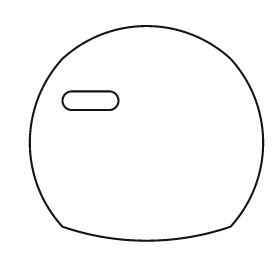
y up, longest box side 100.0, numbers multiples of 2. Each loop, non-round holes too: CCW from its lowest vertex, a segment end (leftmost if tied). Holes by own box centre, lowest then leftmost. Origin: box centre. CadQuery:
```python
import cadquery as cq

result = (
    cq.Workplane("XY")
    .moveTo(-36.0, -40.0)
    .threePointArc((0.0, -46.0), (36.0, -40.0))
    .threePointArc((50.0, -4.0), (36.0, 32.0))
    .threePointArc((0.0, 46.0), (-36.0, 32.0))
    .threePointArc((-50.0, -4.0), (-36.0, -40.0))
    .close()
    .moveTo(-32.0, 10.0)
    .lineTo(-16.0, 10.0)
    .threePointArc((-12.0, 14.0), (-16.0, 18.0))
    .lineTo(-32.0, 18.0)
    .threePointArc((-36.0, 14.0), (-32.0, 10.0))
    .close()
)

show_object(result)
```